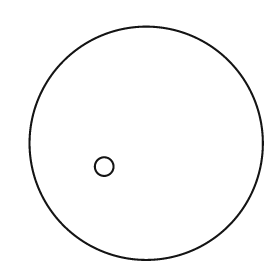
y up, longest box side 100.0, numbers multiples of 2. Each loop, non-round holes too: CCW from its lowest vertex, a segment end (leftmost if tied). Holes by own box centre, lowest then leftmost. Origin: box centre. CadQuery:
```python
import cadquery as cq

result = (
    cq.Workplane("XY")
    .moveTo(0.0, 0.0)
    .circle(50.0)
    .moveTo(-18.0, -10.0)
    .circle(4.0)
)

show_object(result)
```